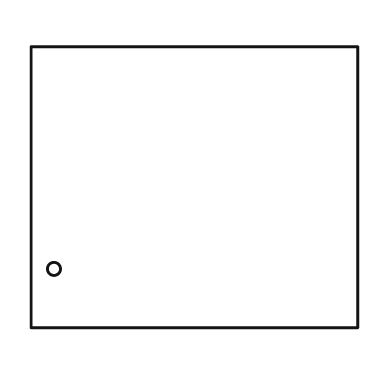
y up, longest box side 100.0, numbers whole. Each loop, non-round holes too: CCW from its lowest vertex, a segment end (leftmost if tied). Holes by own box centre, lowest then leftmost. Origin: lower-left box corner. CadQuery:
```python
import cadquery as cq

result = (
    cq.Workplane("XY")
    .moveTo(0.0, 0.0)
    .lineTo(100.0, 0.0)
    .lineTo(100.0, 86.0)
    .lineTo(0.0, 86.0)
    .close()
    .moveTo(7.0, 18.0)
    .circle(2.0)
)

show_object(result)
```